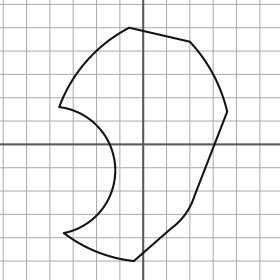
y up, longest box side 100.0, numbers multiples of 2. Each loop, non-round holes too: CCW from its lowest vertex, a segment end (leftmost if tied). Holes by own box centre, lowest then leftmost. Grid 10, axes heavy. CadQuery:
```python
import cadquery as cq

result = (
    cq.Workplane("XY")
    .moveTo(-4.0, -50.0)
    .lineTo(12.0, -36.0)
    .threePointArc((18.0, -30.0), (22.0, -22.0))
    .lineTo(36.0, 14.0)
    .threePointArc((30.0, 30.0), (20.0, 44.0))
    .lineTo(-6.0, 50.0)
    .threePointArc((-24.0, 36.0), (-36.0, 16.0))
    .threePointArc((-12.0, -10.0), (-34.0, -38.0))
    .threePointArc((-20.0, -46.0), (-4.0, -50.0))
    .close()
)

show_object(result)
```